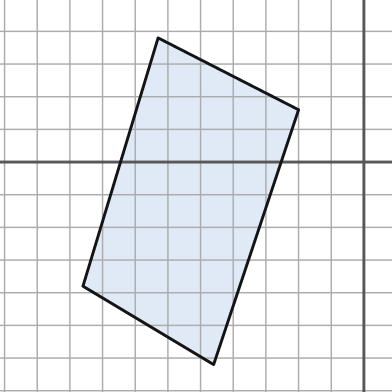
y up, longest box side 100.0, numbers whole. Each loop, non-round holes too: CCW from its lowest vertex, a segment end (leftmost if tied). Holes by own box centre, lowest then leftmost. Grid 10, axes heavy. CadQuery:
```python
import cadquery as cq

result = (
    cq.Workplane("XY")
    .moveTo(-46.0, -62.0)
    .lineTo(-20.0, 16.0)
    .lineTo(-63.0, 38.0)
    .lineTo(-86.0, -38.0)
    .close()
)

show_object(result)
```